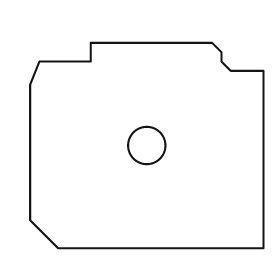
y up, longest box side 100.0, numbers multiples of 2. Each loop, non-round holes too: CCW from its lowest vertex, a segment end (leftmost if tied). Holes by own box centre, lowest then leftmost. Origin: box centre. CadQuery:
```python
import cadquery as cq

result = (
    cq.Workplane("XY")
    .moveTo(-38.0, -44.0)
    .lineTo(50.0, -44.0)
    .lineTo(50.0, 32.0)
    .lineTo(36.0, 32.0)
    .lineTo(32.0, 36.0)
    .lineTo(32.0, 40.0)
    .lineTo(28.0, 44.0)
    .lineTo(-24.0, 44.0)
    .lineTo(-24.0, 36.0)
    .lineTo(-46.0, 36.0)
    .lineTo(-50.0, 26.0)
    .lineTo(-50.0, -32.0)
    .close()
    .moveTo(0.0, 0.0)
    .circle(8.0)
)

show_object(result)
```